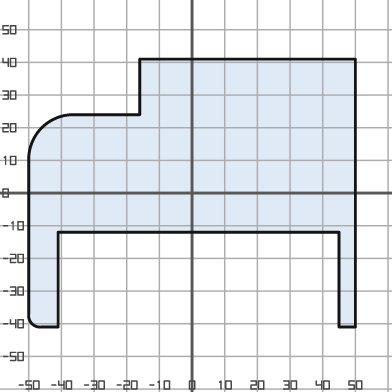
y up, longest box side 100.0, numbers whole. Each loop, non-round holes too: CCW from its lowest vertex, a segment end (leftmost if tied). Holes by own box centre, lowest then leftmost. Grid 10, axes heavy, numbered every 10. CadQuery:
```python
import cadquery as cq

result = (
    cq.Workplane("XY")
    .moveTo(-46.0, -41.0)
    .lineTo(-41.0, -41.0)
    .lineTo(-41.0, -12.0)
    .lineTo(45.0, -12.0)
    .lineTo(45.0, -41.0)
    .lineTo(50.0, -41.0)
    .lineTo(50.0, 41.0)
    .lineTo(-16.0, 41.0)
    .lineTo(-16.0, 24.0)
    .lineTo(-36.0, 24.0)
    .threePointArc((-46.0, 20.0), (-50.0, 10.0))
    .lineTo(-50.0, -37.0)
    .threePointArc((-49.0, -40.0), (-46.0, -41.0))
    .close()
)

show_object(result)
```